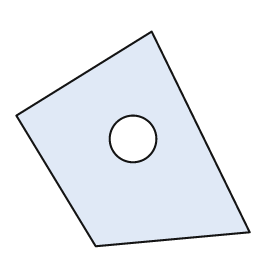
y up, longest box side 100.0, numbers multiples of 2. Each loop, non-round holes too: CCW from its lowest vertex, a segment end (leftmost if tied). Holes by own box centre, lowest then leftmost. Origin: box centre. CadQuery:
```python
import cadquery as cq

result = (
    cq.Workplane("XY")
    .moveTo(-16.0, -46.0)
    .lineTo(50.0, -40.0)
    .lineTo(8.0, 46.0)
    .lineTo(-50.0, 10.0)
    .close()
    .moveTo(0.0, 0.0)
    .circle(10.0)
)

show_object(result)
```